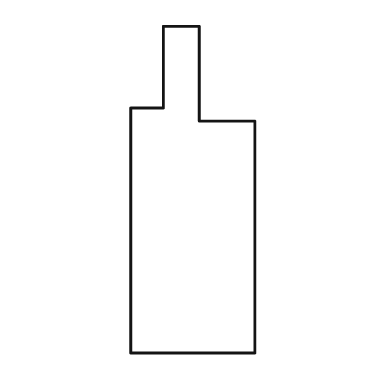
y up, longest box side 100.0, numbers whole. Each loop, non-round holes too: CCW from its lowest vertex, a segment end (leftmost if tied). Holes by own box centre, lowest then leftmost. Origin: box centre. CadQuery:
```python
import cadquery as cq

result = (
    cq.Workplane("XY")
    .moveTo(-19.0, -50.0)
    .lineTo(19.0, -50.0)
    .lineTo(19.0, 21.0)
    .lineTo(2.0, 21.0)
    .lineTo(2.0, 50.0)
    .lineTo(-9.0, 50.0)
    .lineTo(-9.0, 25.0)
    .lineTo(-19.0, 25.0)
    .close()
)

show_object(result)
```